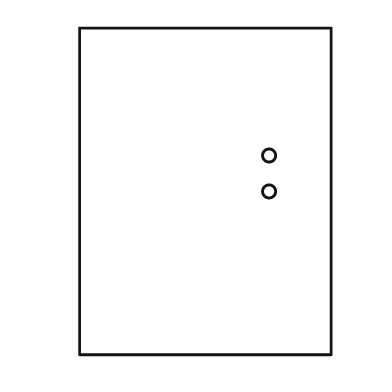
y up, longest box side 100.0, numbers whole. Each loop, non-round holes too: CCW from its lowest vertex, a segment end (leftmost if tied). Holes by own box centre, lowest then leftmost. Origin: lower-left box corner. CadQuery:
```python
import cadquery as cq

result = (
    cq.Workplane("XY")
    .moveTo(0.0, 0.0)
    .lineTo(77.0, 0.0)
    .lineTo(77.0, 100.0)
    .lineTo(0.0, 100.0)
    .close()
    .moveTo(58.0, 50.0)
    .circle(2.0)
    .moveTo(58.0, 61.0)
    .circle(2.0)
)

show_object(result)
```